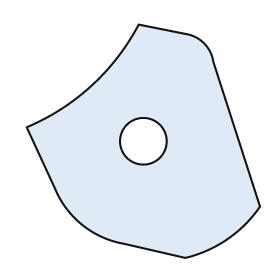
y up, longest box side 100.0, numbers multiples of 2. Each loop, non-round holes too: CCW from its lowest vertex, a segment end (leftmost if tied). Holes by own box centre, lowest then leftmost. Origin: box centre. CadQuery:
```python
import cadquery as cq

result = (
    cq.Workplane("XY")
    .moveTo(18.0, -50.0)
    .threePointArc((36.0, -42.0), (50.0, -28.0))
    .lineTo(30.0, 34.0)
    .threePointArc((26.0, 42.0), (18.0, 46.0))
    .lineTo(-2.0, 50.0)
    .threePointArc((-22.0, 24.0), (-50.0, 6.0))
    .lineTo(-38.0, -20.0)
    .threePointArc((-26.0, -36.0), (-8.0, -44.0))
    .close()
    .moveTo(0.0, 0.0)
    .circle(10.0)
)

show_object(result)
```